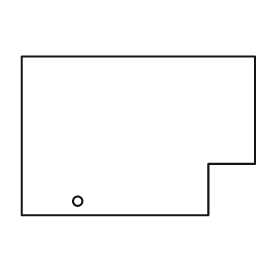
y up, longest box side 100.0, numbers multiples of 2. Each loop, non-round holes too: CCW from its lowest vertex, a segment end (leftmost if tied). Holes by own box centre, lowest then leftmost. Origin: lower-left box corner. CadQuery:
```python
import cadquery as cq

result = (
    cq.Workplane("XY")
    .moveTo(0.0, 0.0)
    .lineTo(80.0, 0.0)
    .lineTo(80.0, 22.0)
    .lineTo(100.0, 22.0)
    .lineTo(100.0, 68.0)
    .lineTo(0.0, 68.0)
    .close()
    .moveTo(24.0, 6.0)
    .circle(2.0)
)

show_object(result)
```